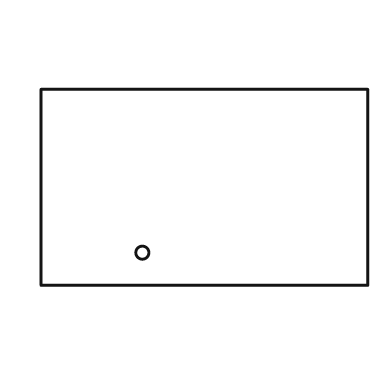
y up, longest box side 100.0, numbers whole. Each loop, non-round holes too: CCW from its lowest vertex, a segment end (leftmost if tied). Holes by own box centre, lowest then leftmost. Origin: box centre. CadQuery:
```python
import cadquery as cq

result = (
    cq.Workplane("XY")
    .moveTo(-50.0, -30.0)
    .lineTo(50.0, -30.0)
    .lineTo(50.0, 30.0)
    .lineTo(-50.0, 30.0)
    .close()
    .moveTo(-19.0, -20.0)
    .circle(2.0)
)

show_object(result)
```